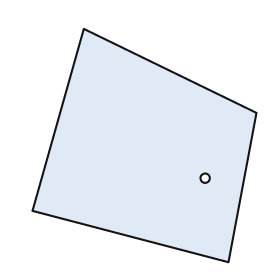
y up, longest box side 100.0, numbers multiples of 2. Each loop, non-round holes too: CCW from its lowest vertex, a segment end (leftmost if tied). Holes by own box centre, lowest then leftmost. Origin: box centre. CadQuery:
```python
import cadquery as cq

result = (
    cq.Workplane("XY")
    .moveTo(36.0, -50.0)
    .lineTo(48.0, 14.0)
    .lineTo(-26.0, 50.0)
    .lineTo(-48.0, -28.0)
    .close()
    .moveTo(26.0, -14.0)
    .circle(2.0)
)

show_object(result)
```